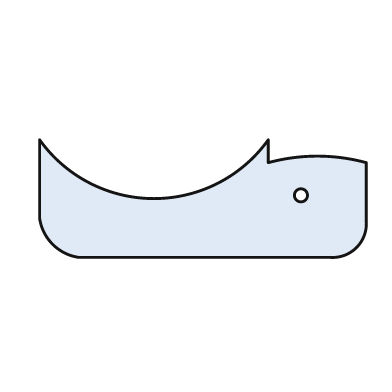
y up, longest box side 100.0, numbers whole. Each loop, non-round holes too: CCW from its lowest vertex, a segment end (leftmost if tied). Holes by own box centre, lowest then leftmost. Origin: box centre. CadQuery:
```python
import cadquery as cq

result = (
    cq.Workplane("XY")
    .moveTo(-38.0, -18.0)
    .lineTo(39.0, -18.0)
    .threePointArc((47.0, -15.0), (50.0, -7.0))
    .lineTo(50.0, 11.0)
    .threePointArc((35.0, 13.0), (20.0, 11.0))
    .lineTo(20.0, 18.0)
    .threePointArc((-15.0, 0.0), (-50.0, 18.0))
    .lineTo(-50.0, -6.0)
    .threePointArc((-46.0, -14.0), (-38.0, -18.0))
    .close()
    .moveTo(30.0, 1.0)
    .circle(2.0)
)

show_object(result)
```